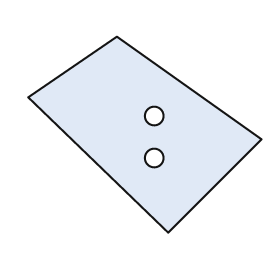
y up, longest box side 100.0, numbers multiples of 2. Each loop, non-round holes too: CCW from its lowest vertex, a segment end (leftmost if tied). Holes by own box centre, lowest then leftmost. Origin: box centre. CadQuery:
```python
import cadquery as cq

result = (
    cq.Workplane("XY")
    .moveTo(10.0, -42.0)
    .lineTo(50.0, -2.0)
    .lineTo(-12.0, 42.0)
    .lineTo(-50.0, 16.0)
    .close()
    .moveTo(4.0, -10.0)
    .circle(4.0)
    .moveTo(4.0, 8.0)
    .circle(4.0)
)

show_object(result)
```